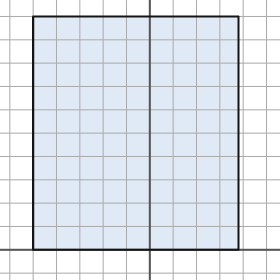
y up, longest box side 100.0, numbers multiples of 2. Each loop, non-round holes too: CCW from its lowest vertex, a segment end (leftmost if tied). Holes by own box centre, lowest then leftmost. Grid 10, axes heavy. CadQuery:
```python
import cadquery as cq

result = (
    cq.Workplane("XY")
    .moveTo(-50.0, 0.0)
    .lineTo(38.0, 0.0)
    .lineTo(38.0, 100.0)
    .lineTo(-50.0, 100.0)
    .close()
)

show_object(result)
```